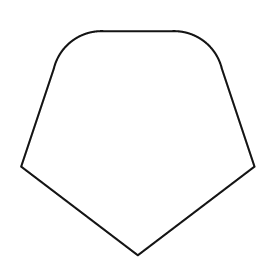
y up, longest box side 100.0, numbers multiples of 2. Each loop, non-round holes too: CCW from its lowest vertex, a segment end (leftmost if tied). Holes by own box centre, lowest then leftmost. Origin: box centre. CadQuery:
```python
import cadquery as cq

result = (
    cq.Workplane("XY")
    .moveTo(0.0, -48.0)
    .lineTo(50.0, -10.0)
    .lineTo(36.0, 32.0)
    .threePointArc((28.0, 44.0), (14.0, 48.0))
    .lineTo(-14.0, 48.0)
    .threePointArc((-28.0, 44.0), (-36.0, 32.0))
    .lineTo(-50.0, -10.0)
    .close()
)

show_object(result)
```